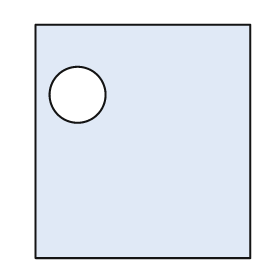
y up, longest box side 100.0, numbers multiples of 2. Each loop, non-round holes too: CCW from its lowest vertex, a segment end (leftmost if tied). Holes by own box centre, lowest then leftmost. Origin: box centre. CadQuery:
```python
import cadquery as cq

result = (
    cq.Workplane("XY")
    .moveTo(-46.0, -50.0)
    .lineTo(46.0, -50.0)
    .lineTo(46.0, 50.0)
    .lineTo(-46.0, 50.0)
    .close()
    .moveTo(-28.0, 20.0)
    .circle(12.0)
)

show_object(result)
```